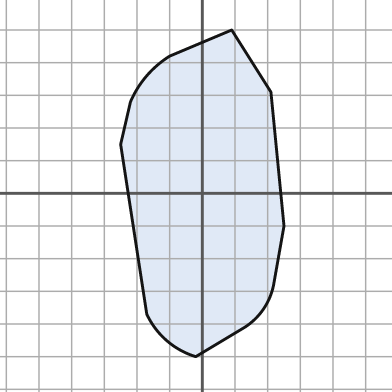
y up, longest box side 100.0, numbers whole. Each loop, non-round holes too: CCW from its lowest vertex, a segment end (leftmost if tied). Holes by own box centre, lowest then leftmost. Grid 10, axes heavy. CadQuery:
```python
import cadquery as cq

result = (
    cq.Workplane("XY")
    .moveTo(-2.0, -50.0)
    .lineTo(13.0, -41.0)
    .threePointArc((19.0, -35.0), (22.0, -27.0))
    .lineTo(25.0, -10.0)
    .lineTo(21.0, 31.0)
    .lineTo(9.0, 50.0)
    .lineTo(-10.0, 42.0)
    .threePointArc((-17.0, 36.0), (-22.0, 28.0))
    .lineTo(-25.0, 15.0)
    .lineTo(-17.0, -37.0)
    .threePointArc((-11.0, -45.0), (-2.0, -50.0))
    .close()
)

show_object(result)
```